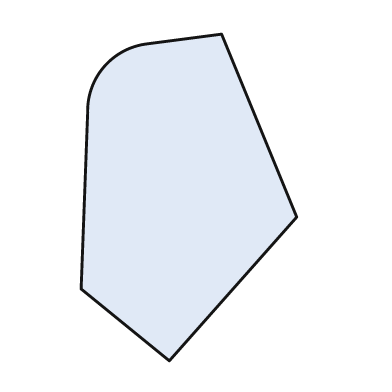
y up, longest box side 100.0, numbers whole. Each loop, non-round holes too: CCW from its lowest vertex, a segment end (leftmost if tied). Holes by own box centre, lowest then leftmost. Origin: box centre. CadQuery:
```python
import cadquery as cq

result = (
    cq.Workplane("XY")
    .moveTo(-6.0, -50.0)
    .lineTo(33.0, -6.0)
    .lineTo(10.0, 50.0)
    .lineTo(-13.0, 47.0)
    .threePointArc((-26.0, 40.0), (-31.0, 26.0))
    .lineTo(-33.0, -28.0)
    .close()
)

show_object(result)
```